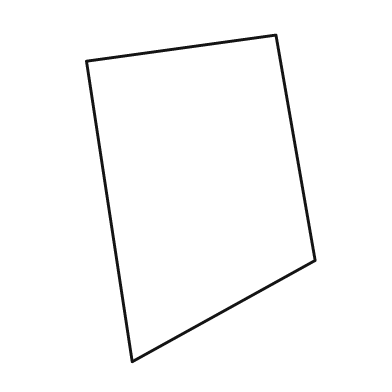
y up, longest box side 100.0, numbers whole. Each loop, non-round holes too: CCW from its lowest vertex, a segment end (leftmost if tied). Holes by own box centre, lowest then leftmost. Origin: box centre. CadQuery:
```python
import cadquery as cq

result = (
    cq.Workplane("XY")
    .moveTo(-21.0, -50.0)
    .lineTo(35.0, -19.0)
    .lineTo(23.0, 50.0)
    .lineTo(-35.0, 42.0)
    .close()
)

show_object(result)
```